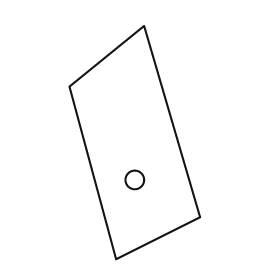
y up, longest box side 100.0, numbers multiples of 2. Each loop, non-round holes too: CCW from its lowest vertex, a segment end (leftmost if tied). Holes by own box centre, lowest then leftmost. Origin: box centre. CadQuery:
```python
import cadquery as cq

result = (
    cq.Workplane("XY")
    .moveTo(-8.0, -50.0)
    .lineTo(28.0, -32.0)
    .lineTo(4.0, 50.0)
    .lineTo(-28.0, 24.0)
    .close()
    .moveTo(0.0, -16.0)
    .circle(4.0)
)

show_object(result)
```